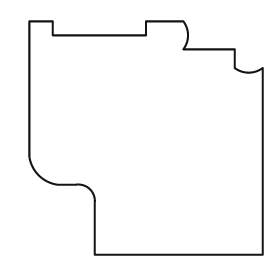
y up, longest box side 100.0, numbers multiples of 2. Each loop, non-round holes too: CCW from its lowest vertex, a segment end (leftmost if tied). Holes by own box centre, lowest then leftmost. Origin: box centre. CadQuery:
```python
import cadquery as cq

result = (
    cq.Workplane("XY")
    .moveTo(-22.0, -50.0)
    .lineTo(50.0, -50.0)
    .lineTo(50.0, 30.0)
    .threePointArc((44.0, 28.0), (38.0, 30.0))
    .lineTo(38.0, 38.0)
    .lineTo(16.0, 38.0)
    .threePointArc((18.0, 44.0), (16.0, 50.0))
    .lineTo(0.0, 50.0)
    .lineTo(0.0, 44.0)
    .lineTo(-40.0, 44.0)
    .lineTo(-40.0, 50.0)
    .lineTo(-50.0, 50.0)
    .lineTo(-50.0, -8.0)
    .threePointArc((-46.0, -16.0), (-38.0, -20.0))
    .lineTo(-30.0, -20.0)
    .threePointArc((-24.0, -22.0), (-22.0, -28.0))
    .close()
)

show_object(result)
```